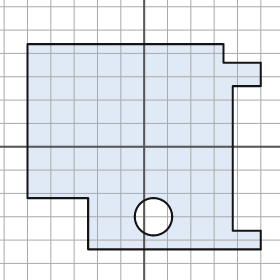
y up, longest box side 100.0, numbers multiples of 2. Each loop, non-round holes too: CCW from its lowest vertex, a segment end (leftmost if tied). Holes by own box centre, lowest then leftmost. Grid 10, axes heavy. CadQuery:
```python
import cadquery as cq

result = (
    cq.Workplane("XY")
    .moveTo(-24.0, -44.0)
    .lineTo(50.0, -44.0)
    .lineTo(50.0, -36.0)
    .lineTo(38.0, -36.0)
    .lineTo(38.0, 26.0)
    .lineTo(50.0, 26.0)
    .lineTo(50.0, 36.0)
    .lineTo(34.0, 36.0)
    .lineTo(34.0, 44.0)
    .lineTo(-50.0, 44.0)
    .lineTo(-50.0, -22.0)
    .lineTo(-24.0, -22.0)
    .close()
    .moveTo(4.0, -30.0)
    .circle(8.0)
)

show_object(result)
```